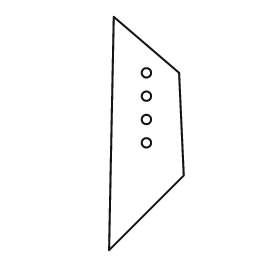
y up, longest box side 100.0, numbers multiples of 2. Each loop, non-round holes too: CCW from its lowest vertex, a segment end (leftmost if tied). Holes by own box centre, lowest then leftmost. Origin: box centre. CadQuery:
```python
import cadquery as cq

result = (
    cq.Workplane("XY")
    .moveTo(-16.0, -50.0)
    .lineTo(16.0, -18.0)
    .lineTo(14.0, 26.0)
    .lineTo(-14.0, 50.0)
    .close()
    .moveTo(0.0, -4.0)
    .circle(2.0)
    .moveTo(0.0, 6.0)
    .circle(2.0)
    .moveTo(0.0, 16.0)
    .circle(2.0)
    .moveTo(0.0, 26.0)
    .circle(2.0)
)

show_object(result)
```